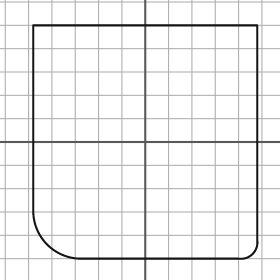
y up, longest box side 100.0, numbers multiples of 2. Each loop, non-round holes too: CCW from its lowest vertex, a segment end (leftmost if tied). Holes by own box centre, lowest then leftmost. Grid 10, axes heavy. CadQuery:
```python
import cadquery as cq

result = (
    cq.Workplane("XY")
    .moveTo(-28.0, -50.0)
    .lineTo(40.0, -50.0)
    .threePointArc((46.0, -48.0), (48.0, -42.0))
    .lineTo(48.0, 50.0)
    .lineTo(-48.0, 50.0)
    .lineTo(-48.0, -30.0)
    .threePointArc((-42.0, -44.0), (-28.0, -50.0))
    .close()
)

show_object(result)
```